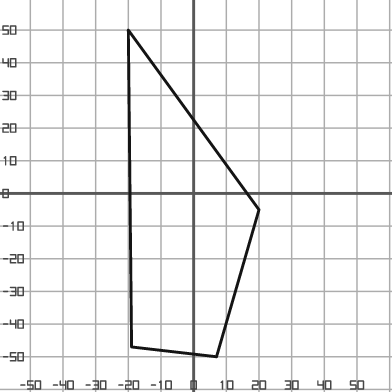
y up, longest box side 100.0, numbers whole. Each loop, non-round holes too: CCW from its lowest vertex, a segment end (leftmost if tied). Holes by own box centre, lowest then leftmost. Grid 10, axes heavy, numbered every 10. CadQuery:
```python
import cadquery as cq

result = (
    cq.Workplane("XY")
    .moveTo(7.0, -50.0)
    .lineTo(20.0, -5.0)
    .lineTo(-20.0, 50.0)
    .lineTo(-19.0, -47.0)
    .close()
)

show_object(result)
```